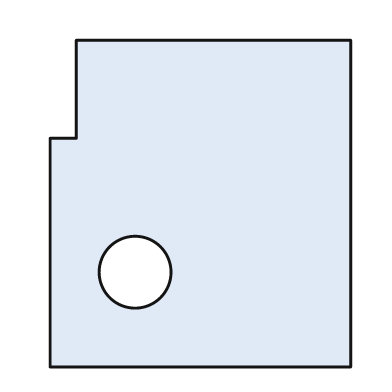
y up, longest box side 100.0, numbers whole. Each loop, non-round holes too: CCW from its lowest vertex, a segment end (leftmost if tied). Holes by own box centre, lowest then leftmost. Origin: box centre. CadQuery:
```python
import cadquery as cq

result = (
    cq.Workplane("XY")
    .moveTo(-46.0, -50.0)
    .lineTo(46.0, -50.0)
    .lineTo(46.0, 50.0)
    .lineTo(-38.0, 50.0)
    .lineTo(-38.0, 20.0)
    .lineTo(-46.0, 20.0)
    .close()
    .moveTo(-20.0, -21.0)
    .circle(11.0)
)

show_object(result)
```